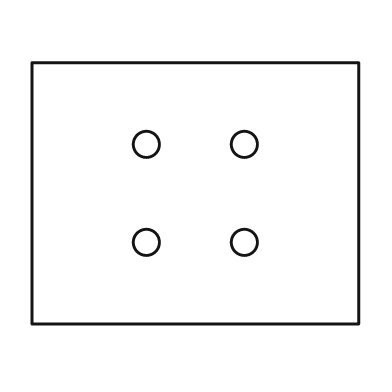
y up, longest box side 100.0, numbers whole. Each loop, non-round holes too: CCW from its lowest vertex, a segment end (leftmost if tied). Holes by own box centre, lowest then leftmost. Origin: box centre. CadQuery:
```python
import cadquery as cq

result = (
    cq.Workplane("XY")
    .moveTo(-50.0, -40.0)
    .lineTo(50.0, -40.0)
    .lineTo(50.0, 40.0)
    .lineTo(-50.0, 40.0)
    .close()
    .moveTo(-15.0, -15.0)
    .circle(4.0)
    .moveTo(15.0, -15.0)
    .circle(4.0)
    .moveTo(-15.0, 15.0)
    .circle(4.0)
    .moveTo(15.0, 15.0)
    .circle(4.0)
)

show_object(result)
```